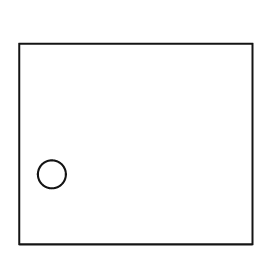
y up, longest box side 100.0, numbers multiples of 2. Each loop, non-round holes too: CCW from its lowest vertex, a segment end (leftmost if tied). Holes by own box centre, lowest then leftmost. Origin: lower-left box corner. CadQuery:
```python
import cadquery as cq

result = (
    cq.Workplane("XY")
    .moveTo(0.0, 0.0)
    .lineTo(100.0, 0.0)
    .lineTo(100.0, 86.0)
    .lineTo(0.0, 86.0)
    .close()
    .moveTo(14.0, 30.0)
    .circle(6.0)
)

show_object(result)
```